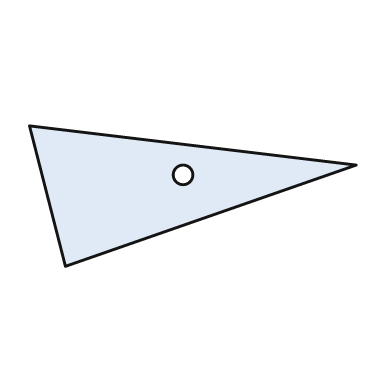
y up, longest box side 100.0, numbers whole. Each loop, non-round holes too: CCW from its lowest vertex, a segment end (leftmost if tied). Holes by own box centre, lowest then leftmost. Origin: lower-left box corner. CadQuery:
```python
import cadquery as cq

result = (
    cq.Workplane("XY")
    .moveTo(11.0, 0.0)
    .lineTo(100.0, 31.0)
    .lineTo(0.0, 43.0)
    .close()
    .moveTo(47.0, 28.0)
    .circle(3.0)
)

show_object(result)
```